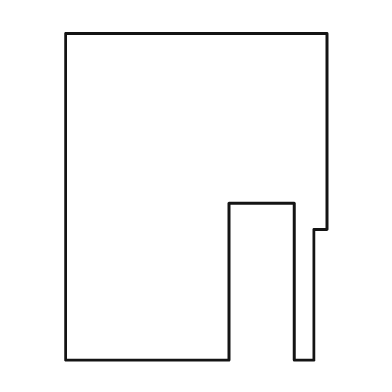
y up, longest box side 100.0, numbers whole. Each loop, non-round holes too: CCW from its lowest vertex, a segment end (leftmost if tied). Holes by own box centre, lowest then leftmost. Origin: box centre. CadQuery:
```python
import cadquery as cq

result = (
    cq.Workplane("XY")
    .moveTo(-40.0, -50.0)
    .lineTo(10.0, -50.0)
    .lineTo(10.0, -2.0)
    .lineTo(30.0, -2.0)
    .lineTo(30.0, -50.0)
    .lineTo(36.0, -50.0)
    .lineTo(36.0, -10.0)
    .lineTo(40.0, -10.0)
    .lineTo(40.0, 50.0)
    .lineTo(-40.0, 50.0)
    .close()
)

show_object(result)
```